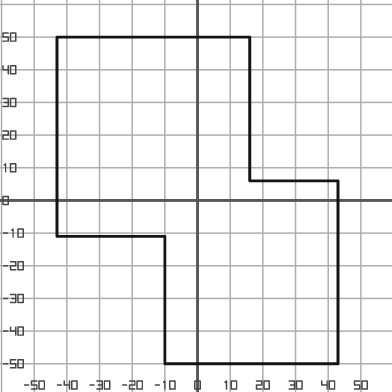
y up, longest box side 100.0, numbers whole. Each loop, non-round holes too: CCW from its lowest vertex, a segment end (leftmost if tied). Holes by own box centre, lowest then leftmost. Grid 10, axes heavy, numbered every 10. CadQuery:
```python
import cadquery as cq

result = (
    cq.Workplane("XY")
    .moveTo(-10.0, -50.0)
    .lineTo(43.0, -50.0)
    .lineTo(43.0, 6.0)
    .lineTo(16.0, 6.0)
    .lineTo(16.0, 50.0)
    .lineTo(-43.0, 50.0)
    .lineTo(-43.0, -11.0)
    .lineTo(-10.0, -11.0)
    .close()
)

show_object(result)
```